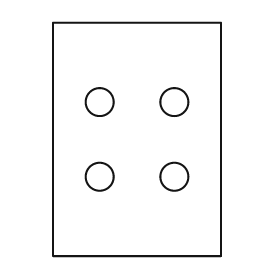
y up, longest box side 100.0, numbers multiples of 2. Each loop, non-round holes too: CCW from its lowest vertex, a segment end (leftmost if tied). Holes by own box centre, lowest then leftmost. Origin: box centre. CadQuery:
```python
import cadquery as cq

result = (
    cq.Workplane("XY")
    .moveTo(-36.0, -50.0)
    .lineTo(36.0, -50.0)
    .lineTo(36.0, 50.0)
    .lineTo(-36.0, 50.0)
    .close()
    .moveTo(-16.0, -16.0)
    .circle(6.0)
    .moveTo(16.0, -16.0)
    .circle(6.0)
    .moveTo(-16.0, 16.0)
    .circle(6.0)
    .moveTo(16.0, 16.0)
    .circle(6.0)
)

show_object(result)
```